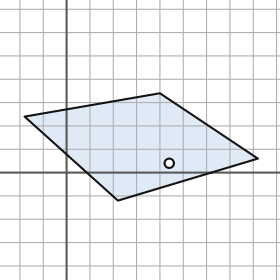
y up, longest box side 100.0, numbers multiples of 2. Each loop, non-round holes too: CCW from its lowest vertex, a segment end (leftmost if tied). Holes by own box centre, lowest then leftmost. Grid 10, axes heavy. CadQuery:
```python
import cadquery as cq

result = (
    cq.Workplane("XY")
    .moveTo(22.0, -12.0)
    .lineTo(82.0, 6.0)
    .lineTo(40.0, 34.0)
    .lineTo(-18.0, 24.0)
    .close()
    .moveTo(44.0, 4.0)
    .circle(2.0)
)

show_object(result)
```